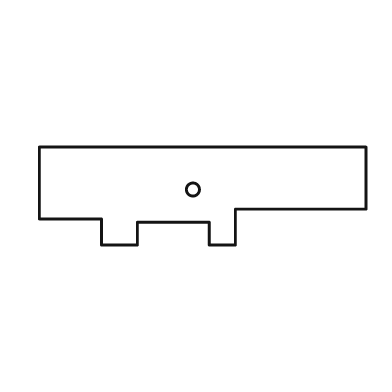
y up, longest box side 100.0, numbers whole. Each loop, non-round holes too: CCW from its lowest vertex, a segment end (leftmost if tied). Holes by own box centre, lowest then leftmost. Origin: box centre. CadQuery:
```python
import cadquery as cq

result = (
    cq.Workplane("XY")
    .moveTo(-31.0, -15.0)
    .lineTo(-20.0, -15.0)
    .lineTo(-20.0, -8.0)
    .lineTo(2.0, -8.0)
    .lineTo(2.0, -15.0)
    .lineTo(10.0, -15.0)
    .lineTo(10.0, -4.0)
    .lineTo(50.0, -4.0)
    .lineTo(50.0, 15.0)
    .lineTo(-50.0, 15.0)
    .lineTo(-50.0, -7.0)
    .lineTo(-31.0, -7.0)
    .close()
    .moveTo(-3.0, 2.0)
    .circle(2.0)
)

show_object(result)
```